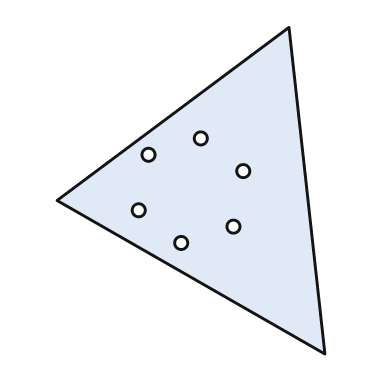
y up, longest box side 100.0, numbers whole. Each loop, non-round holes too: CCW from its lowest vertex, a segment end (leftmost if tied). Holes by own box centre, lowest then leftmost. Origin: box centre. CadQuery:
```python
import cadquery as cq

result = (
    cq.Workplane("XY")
    .moveTo(41.0, -50.0)
    .lineTo(30.0, 50.0)
    .lineTo(-41.0, -3.0)
    .close()
    .moveTo(-3.0, -16.0)
    .circle(2.0)
    .moveTo(13.0, -11.0)
    .circle(2.0)
    .moveTo(-16.0, -6.0)
    .circle(2.0)
    .moveTo(16.0, 6.0)
    .circle(2.0)
    .moveTo(-13.0, 11.0)
    .circle(2.0)
    .moveTo(3.0, 16.0)
    .circle(2.0)
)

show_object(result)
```